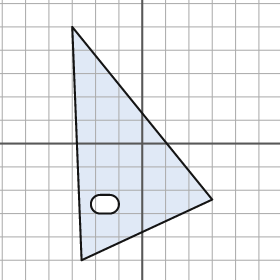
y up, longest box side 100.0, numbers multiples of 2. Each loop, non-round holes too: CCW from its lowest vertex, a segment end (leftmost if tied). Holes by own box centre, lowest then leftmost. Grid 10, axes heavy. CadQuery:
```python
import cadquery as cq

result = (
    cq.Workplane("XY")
    .moveTo(-26.0, -50.0)
    .lineTo(30.0, -24.0)
    .lineTo(-30.0, 50.0)
    .close()
    .moveTo(-18.0, -30.0)
    .lineTo(-14.0, -30.0)
    .threePointArc((-10.0, -26.0), (-14.0, -22.0))
    .lineTo(-18.0, -22.0)
    .threePointArc((-22.0, -26.0), (-18.0, -30.0))
    .close()
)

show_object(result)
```